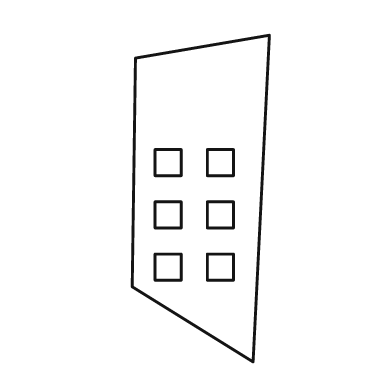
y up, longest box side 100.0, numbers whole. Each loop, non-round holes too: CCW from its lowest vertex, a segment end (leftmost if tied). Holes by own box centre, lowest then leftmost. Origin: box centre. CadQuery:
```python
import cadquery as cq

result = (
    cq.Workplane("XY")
    .moveTo(16.0, -50.0)
    .lineTo(21.0, 50.0)
    .lineTo(-20.0, 43.0)
    .lineTo(-21.0, -27.0)
    .close()
    .moveTo(-14.0, -25.0)
    .lineTo(-6.0, -25.0)
    .lineTo(-6.0, -17.0)
    .lineTo(-14.0, -17.0)
    .close()
    .moveTo(2.0, -25.0)
    .lineTo(10.0, -25.0)
    .lineTo(10.0, -17.0)
    .lineTo(2.0, -17.0)
    .close()
    .moveTo(-14.0, -9.0)
    .lineTo(-6.0, -9.0)
    .lineTo(-6.0, -1.0)
    .lineTo(-14.0, -1.0)
    .close()
    .moveTo(2.0, -9.0)
    .lineTo(10.0, -9.0)
    .lineTo(10.0, -1.0)
    .lineTo(2.0, -1.0)
    .close()
    .moveTo(-14.0, 7.0)
    .lineTo(-6.0, 7.0)
    .lineTo(-6.0, 15.0)
    .lineTo(-14.0, 15.0)
    .close()
    .moveTo(2.0, 7.0)
    .lineTo(10.0, 7.0)
    .lineTo(10.0, 15.0)
    .lineTo(2.0, 15.0)
    .close()
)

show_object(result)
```